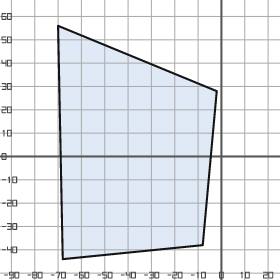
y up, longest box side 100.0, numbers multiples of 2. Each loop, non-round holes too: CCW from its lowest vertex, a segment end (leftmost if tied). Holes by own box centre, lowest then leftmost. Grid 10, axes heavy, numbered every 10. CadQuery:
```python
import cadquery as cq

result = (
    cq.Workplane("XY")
    .moveTo(-68.0, -44.0)
    .lineTo(-8.0, -38.0)
    .lineTo(-2.0, 28.0)
    .lineTo(-70.0, 56.0)
    .close()
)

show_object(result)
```